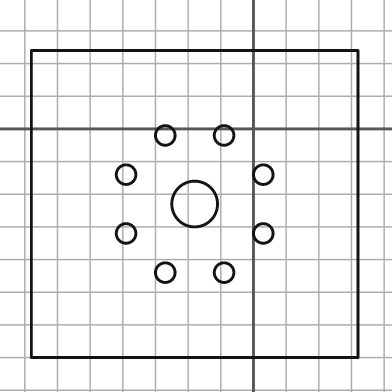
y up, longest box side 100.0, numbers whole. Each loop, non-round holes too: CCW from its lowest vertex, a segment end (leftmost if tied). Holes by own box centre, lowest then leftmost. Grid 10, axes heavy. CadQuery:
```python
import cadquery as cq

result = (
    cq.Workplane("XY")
    .moveTo(-68.0, -70.0)
    .lineTo(32.0, -70.0)
    .lineTo(32.0, 24.0)
    .lineTo(-68.0, 24.0)
    .close()
    .moveTo(-27.0, -44.0)
    .circle(3.0)
    .moveTo(-9.0, -44.0)
    .circle(3.0)
    .moveTo(-39.0, -32.0)
    .circle(3.0)
    .moveTo(3.0, -32.0)
    .circle(3.0)
    .moveTo(-18.0, -23.0)
    .circle(7.0)
    .moveTo(-39.0, -14.0)
    .circle(3.0)
    .moveTo(3.0, -14.0)
    .circle(3.0)
    .moveTo(-27.0, -2.0)
    .circle(3.0)
    .moveTo(-9.0, -2.0)
    .circle(3.0)
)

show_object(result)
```